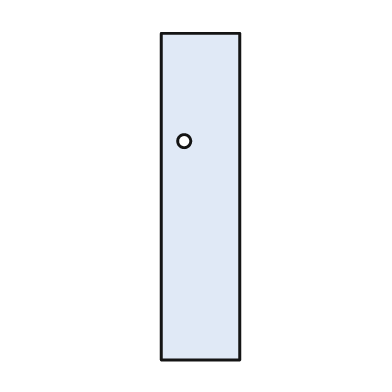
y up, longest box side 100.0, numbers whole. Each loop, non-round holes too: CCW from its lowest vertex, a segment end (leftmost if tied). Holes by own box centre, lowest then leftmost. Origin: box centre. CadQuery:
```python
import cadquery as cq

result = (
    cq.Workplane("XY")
    .moveTo(-12.0, -50.0)
    .lineTo(12.0, -50.0)
    .lineTo(12.0, 50.0)
    .lineTo(-12.0, 50.0)
    .close()
    .moveTo(-5.0, 17.0)
    .circle(2.0)
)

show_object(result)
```